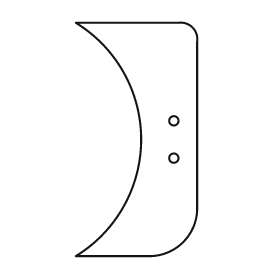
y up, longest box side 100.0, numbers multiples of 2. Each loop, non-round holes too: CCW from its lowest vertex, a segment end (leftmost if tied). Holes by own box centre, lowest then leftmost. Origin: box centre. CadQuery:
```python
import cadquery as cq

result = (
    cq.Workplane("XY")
    .moveTo(-26.0, -50.0)
    .lineTo(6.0, -50.0)
    .threePointArc((20.0, -44.0), (26.0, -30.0))
    .lineTo(26.0, 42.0)
    .threePointArc((24.0, 48.0), (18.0, 50.0))
    .lineTo(-26.0, 50.0)
    .threePointArc((2.0, 0.0), (-26.0, -50.0))
    .close()
    .moveTo(16.0, -8.0)
    .circle(2.0)
    .moveTo(16.0, 8.0)
    .circle(2.0)
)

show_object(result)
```